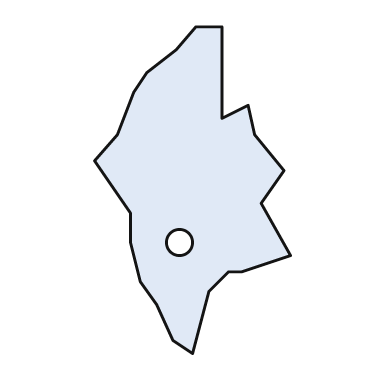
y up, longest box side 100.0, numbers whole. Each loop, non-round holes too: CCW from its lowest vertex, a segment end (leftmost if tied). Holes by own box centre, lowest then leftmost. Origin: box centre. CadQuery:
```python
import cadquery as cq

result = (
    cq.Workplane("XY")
    .moveTo(0.0, -50.0)
    .lineTo(5.0, -31.0)
    .lineTo(11.0, -25.0)
    .lineTo(15.0, -25.0)
    .lineTo(30.0, -20.0)
    .lineTo(21.0, -4.0)
    .lineTo(28.0, 6.0)
    .lineTo(19.0, 17.0)
    .lineTo(17.0, 26.0)
    .lineTo(9.0, 22.0)
    .lineTo(9.0, 50.0)
    .lineTo(1.0, 50.0)
    .lineTo(-5.0, 43.0)
    .lineTo(-14.0, 36.0)
    .lineTo(-18.0, 30.0)
    .lineTo(-23.0, 17.0)
    .lineTo(-30.0, 9.0)
    .lineTo(-19.0, -7.0)
    .lineTo(-19.0, -16.0)
    .lineTo(-16.0, -28.0)
    .lineTo(-11.0, -35.0)
    .lineTo(-6.0, -46.0)
    .close()
    .moveTo(-4.0, -16.0)
    .circle(4.0)
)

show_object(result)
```